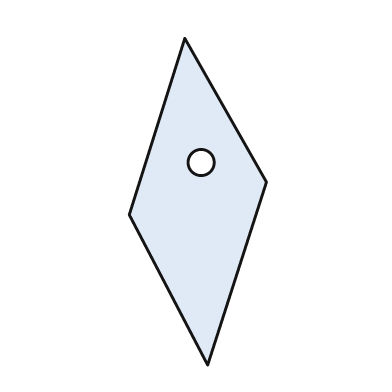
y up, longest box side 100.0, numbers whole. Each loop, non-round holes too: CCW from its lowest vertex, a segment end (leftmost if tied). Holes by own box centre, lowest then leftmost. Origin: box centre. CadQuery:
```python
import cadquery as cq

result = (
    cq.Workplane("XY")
    .moveTo(3.0, -50.0)
    .lineTo(21.0, 6.0)
    .lineTo(-4.0, 50.0)
    .lineTo(-21.0, -4.0)
    .close()
    .moveTo(1.0, 12.0)
    .circle(4.0)
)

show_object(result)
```